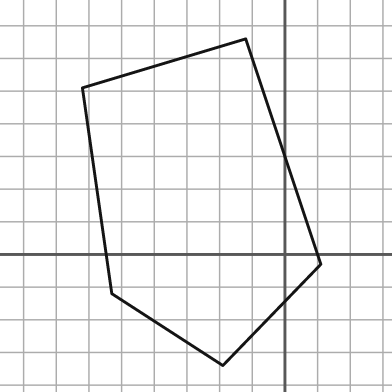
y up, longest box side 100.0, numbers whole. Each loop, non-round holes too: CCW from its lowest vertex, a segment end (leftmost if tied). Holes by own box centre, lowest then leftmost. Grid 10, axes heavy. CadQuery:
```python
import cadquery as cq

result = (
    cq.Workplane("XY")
    .moveTo(-19.0, -34.0)
    .lineTo(11.0, -3.0)
    .lineTo(-12.0, 66.0)
    .lineTo(-62.0, 51.0)
    .lineTo(-53.0, -12.0)
    .close()
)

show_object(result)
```